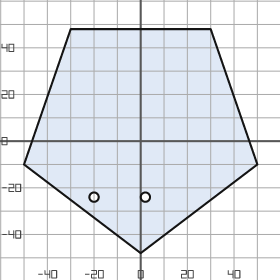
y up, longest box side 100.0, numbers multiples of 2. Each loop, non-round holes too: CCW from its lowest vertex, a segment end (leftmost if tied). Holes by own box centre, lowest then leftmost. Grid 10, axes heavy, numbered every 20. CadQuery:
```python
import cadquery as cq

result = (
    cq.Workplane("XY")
    .moveTo(0.0, -48.0)
    .lineTo(50.0, -10.0)
    .lineTo(30.0, 48.0)
    .lineTo(-30.0, 48.0)
    .lineTo(-50.0, -10.0)
    .close()
    .moveTo(-20.0, -24.0)
    .circle(2.0)
    .moveTo(2.0, -24.0)
    .circle(2.0)
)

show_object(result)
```